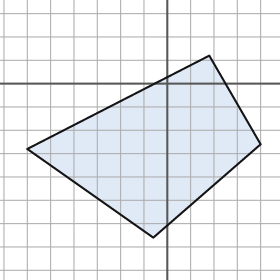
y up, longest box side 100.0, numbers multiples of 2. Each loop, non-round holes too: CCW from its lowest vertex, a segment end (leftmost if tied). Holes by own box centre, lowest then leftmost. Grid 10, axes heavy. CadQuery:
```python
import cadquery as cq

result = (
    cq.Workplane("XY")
    .moveTo(-6.0, -66.0)
    .lineTo(40.0, -26.0)
    .lineTo(18.0, 12.0)
    .lineTo(-60.0, -28.0)
    .close()
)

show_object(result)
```